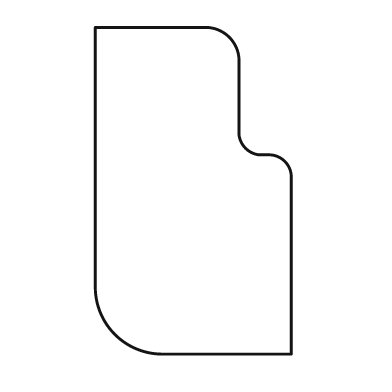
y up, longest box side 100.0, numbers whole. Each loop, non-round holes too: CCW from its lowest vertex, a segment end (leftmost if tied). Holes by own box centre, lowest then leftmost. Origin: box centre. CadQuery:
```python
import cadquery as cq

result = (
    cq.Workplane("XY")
    .moveTo(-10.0, -50.0)
    .lineTo(30.0, -50.0)
    .lineTo(30.0, 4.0)
    .threePointArc((28.0, 9.0), (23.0, 11.0))
    .lineTo(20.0, 11.0)
    .threePointArc((16.0, 13.0), (14.0, 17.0))
    .lineTo(14.0, 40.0)
    .threePointArc((11.0, 47.0), (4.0, 50.0))
    .lineTo(-30.0, 50.0)
    .lineTo(-30.0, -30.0)
    .threePointArc((-24.0, -44.0), (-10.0, -50.0))
    .close()
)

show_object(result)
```